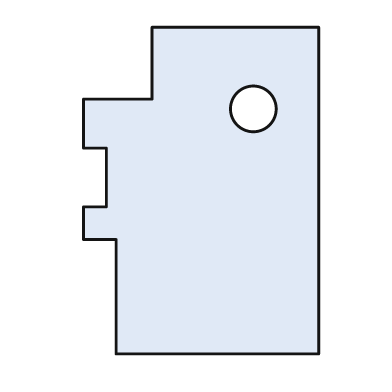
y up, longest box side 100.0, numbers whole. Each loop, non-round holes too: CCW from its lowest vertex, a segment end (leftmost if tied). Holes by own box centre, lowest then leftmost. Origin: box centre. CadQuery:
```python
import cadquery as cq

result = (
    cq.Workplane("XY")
    .moveTo(-26.0, -50.0)
    .lineTo(36.0, -50.0)
    .lineTo(36.0, 50.0)
    .lineTo(-15.0, 50.0)
    .lineTo(-15.0, 28.0)
    .lineTo(-36.0, 28.0)
    .lineTo(-36.0, 13.0)
    .lineTo(-29.0, 13.0)
    .lineTo(-29.0, -5.0)
    .lineTo(-36.0, -5.0)
    .lineTo(-36.0, -15.0)
    .lineTo(-26.0, -15.0)
    .close()
    .moveTo(16.0, 25.0)
    .circle(7.0)
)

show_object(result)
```